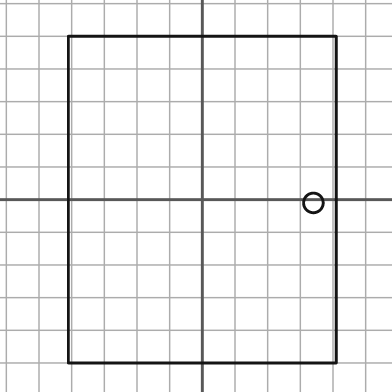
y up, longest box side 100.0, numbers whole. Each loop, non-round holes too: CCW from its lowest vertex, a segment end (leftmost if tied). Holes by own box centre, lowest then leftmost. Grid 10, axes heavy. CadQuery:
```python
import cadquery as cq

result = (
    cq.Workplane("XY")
    .moveTo(-41.0, -50.0)
    .lineTo(41.0, -50.0)
    .lineTo(41.0, 50.0)
    .lineTo(-41.0, 50.0)
    .close()
    .moveTo(34.0, -1.0)
    .circle(3.0)
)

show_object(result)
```